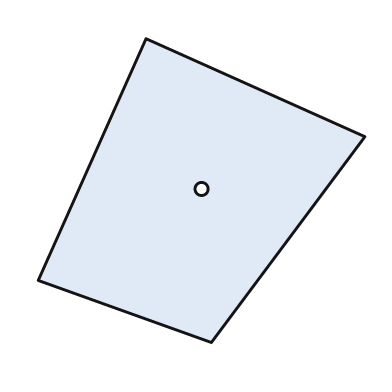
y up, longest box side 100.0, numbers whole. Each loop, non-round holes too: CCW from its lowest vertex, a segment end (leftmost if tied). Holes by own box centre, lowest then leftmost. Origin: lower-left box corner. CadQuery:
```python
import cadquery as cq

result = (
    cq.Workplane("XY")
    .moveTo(53.0, 0.0)
    .lineTo(100.0, 63.0)
    .lineTo(33.0, 93.0)
    .lineTo(0.0, 19.0)
    .close()
    .moveTo(50.0, 47.0)
    .circle(2.0)
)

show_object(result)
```